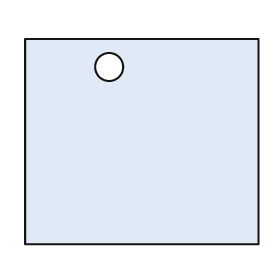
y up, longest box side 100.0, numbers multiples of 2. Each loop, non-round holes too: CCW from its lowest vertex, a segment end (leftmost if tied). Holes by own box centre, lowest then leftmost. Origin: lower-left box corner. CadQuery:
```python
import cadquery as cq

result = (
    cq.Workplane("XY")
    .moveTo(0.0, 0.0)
    .lineTo(100.0, 0.0)
    .lineTo(100.0, 88.0)
    .lineTo(0.0, 88.0)
    .close()
    .moveTo(36.0, 76.0)
    .circle(6.0)
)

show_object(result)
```